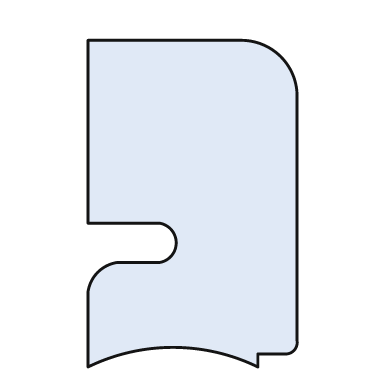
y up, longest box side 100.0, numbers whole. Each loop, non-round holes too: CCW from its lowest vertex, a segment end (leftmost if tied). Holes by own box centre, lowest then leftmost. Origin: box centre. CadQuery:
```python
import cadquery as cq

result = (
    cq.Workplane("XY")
    .moveTo(-32.0, -50.0)
    .threePointArc((-6.0, -44.0), (20.0, -50.0))
    .lineTo(20.0, -46.0)
    .lineTo(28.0, -46.0)
    .threePointArc((31.0, -45.0), (32.0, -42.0))
    .lineTo(32.0, 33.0)
    .threePointArc((27.0, 45.0), (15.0, 50.0))
    .lineTo(-32.0, 50.0)
    .lineTo(-32.0, -6.0)
    .lineTo(-10.0, -6.0)
    .threePointArc((-5.0, -12.0), (-10.0, -18.0))
    .lineTo(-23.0, -18.0)
    .threePointArc((-29.0, -21.0), (-32.0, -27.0))
    .close()
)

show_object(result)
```